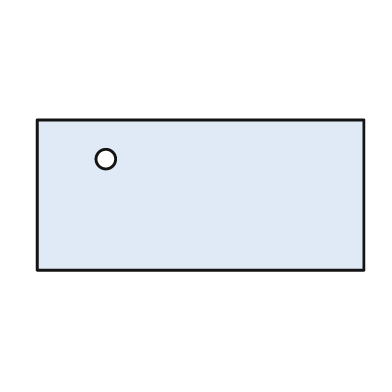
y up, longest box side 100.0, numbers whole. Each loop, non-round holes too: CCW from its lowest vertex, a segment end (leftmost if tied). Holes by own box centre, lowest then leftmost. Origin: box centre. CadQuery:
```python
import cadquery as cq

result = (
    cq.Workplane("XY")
    .moveTo(-50.0, -23.0)
    .lineTo(50.0, -23.0)
    .lineTo(50.0, 23.0)
    .lineTo(-50.0, 23.0)
    .close()
    .moveTo(-29.0, 11.0)
    .circle(3.0)
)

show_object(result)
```